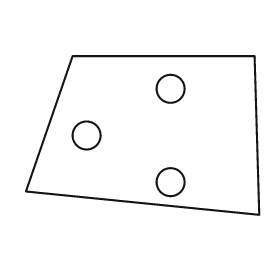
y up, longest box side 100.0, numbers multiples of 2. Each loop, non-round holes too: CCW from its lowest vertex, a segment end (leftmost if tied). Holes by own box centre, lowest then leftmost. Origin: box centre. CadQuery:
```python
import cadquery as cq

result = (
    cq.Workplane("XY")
    .moveTo(50.0, -34.0)
    .lineTo(48.0, 34.0)
    .lineTo(-30.0, 34.0)
    .lineTo(-50.0, -24.0)
    .close()
    .moveTo(12.0, -20.0)
    .circle(6.0)
    .moveTo(-24.0, 0.0)
    .circle(6.0)
    .moveTo(12.0, 20.0)
    .circle(6.0)
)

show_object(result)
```